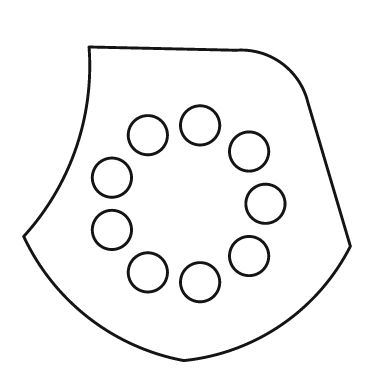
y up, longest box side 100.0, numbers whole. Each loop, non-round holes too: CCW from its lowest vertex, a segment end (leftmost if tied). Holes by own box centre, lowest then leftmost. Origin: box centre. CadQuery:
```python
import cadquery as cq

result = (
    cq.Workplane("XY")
    .moveTo(-1.0, -48.0)
    .threePointArc((29.0, -37.0), (50.0, -13.0))
    .lineTo(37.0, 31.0)
    .threePointArc((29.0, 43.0), (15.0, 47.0))
    .lineTo(-30.0, 48.0)
    .threePointArc((-34.0, 17.0), (-50.0, -10.0))
    .threePointArc((-30.0, -35.0), (-1.0, -48.0))
    .close()
    .moveTo(4.0, -24.0)
    .circle(6.0)
    .moveTo(-12.0, -21.0)
    .circle(6.0)
    .moveTo(19.0, -16.0)
    .circle(6.0)
    .moveTo(-23.0, -8.0)
    .circle(6.0)
    .moveTo(24.0, 0.0)
    .circle(6.0)
    .moveTo(-23.0, 8.0)
    .circle(6.0)
    .moveTo(19.0, 16.0)
    .circle(6.0)
    .moveTo(-12.0, 21.0)
    .circle(6.0)
    .moveTo(4.0, 24.0)
    .circle(6.0)
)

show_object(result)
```